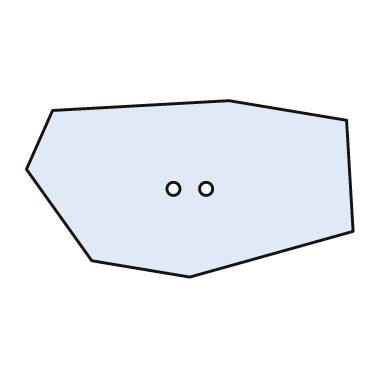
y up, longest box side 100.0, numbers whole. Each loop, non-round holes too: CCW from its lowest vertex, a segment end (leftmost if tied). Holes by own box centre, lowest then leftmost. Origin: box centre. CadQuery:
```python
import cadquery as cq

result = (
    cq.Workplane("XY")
    .moveTo(0.0, -27.0)
    .lineTo(50.0, -13.0)
    .lineTo(48.0, 21.0)
    .lineTo(12.0, 27.0)
    .lineTo(-42.0, 24.0)
    .lineTo(-50.0, 6.0)
    .lineTo(-30.0, -22.0)
    .close()
    .moveTo(-5.0, 0.0)
    .circle(2.0)
    .moveTo(5.0, 0.0)
    .circle(2.0)
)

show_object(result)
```